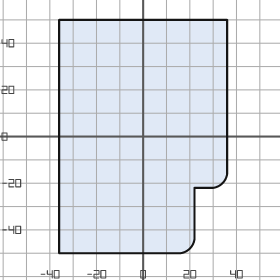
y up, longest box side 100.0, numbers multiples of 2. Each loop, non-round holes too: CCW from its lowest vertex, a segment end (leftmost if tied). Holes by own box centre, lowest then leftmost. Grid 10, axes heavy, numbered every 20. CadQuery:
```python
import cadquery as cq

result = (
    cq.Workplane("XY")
    .moveTo(-36.0, -50.0)
    .lineTo(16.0, -50.0)
    .threePointArc((20.0, -48.0), (22.0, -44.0))
    .lineTo(22.0, -22.0)
    .lineTo(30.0, -22.0)
    .threePointArc((34.0, -20.0), (36.0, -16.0))
    .lineTo(36.0, 50.0)
    .lineTo(-36.0, 50.0)
    .close()
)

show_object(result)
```